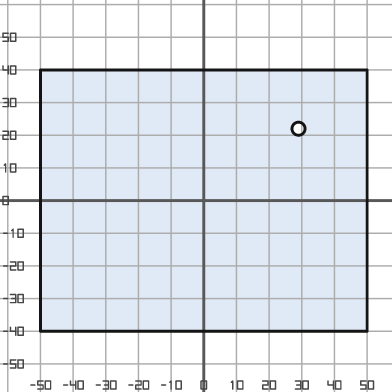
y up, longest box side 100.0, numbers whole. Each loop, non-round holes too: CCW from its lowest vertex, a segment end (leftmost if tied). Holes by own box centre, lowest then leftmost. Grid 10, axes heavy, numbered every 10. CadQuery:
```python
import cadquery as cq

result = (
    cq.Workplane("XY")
    .moveTo(-50.0, -40.0)
    .lineTo(50.0, -40.0)
    .lineTo(50.0, 40.0)
    .lineTo(-50.0, 40.0)
    .close()
    .moveTo(29.0, 22.0)
    .circle(2.0)
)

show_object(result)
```